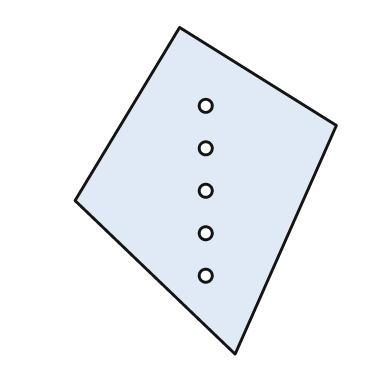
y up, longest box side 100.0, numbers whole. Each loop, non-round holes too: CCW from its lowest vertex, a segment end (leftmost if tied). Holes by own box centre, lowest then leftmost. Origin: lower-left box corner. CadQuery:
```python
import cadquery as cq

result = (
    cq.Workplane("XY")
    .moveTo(49.0, 0.0)
    .lineTo(80.0, 70.0)
    .lineTo(32.0, 100.0)
    .lineTo(0.0, 47.0)
    .close()
    .moveTo(40.0, 24.0)
    .circle(2.0)
    .moveTo(40.0, 37.0)
    .circle(2.0)
    .moveTo(40.0, 50.0)
    .circle(2.0)
    .moveTo(40.0, 63.0)
    .circle(2.0)
    .moveTo(40.0, 76.0)
    .circle(2.0)
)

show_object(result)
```